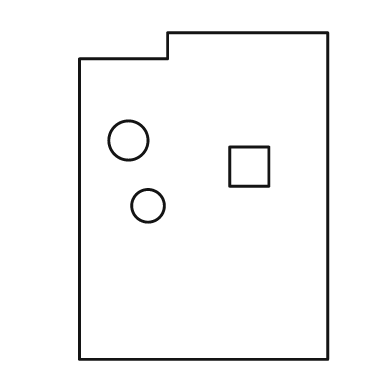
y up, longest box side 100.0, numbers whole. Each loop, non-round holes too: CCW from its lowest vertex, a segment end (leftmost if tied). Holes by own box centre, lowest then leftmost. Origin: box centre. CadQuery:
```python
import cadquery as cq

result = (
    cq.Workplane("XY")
    .moveTo(-38.0, -50.0)
    .lineTo(38.0, -50.0)
    .lineTo(38.0, 50.0)
    .lineTo(-11.0, 50.0)
    .lineTo(-11.0, 42.0)
    .lineTo(-38.0, 42.0)
    .close()
    .moveTo(-17.0, -3.0)
    .circle(5.0)
    .moveTo(8.0, 3.0)
    .lineTo(20.0, 3.0)
    .lineTo(20.0, 15.0)
    .lineTo(8.0, 15.0)
    .close()
    .moveTo(-23.0, 17.0)
    .circle(6.0)
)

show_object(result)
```